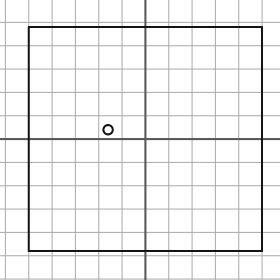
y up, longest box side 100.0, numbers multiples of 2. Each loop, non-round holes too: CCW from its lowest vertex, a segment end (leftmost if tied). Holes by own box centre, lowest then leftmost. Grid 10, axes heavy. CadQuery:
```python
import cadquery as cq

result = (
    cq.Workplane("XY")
    .moveTo(-50.0, -48.0)
    .lineTo(50.0, -48.0)
    .lineTo(50.0, 48.0)
    .lineTo(-50.0, 48.0)
    .close()
    .moveTo(-16.0, 4.0)
    .circle(2.0)
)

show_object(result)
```